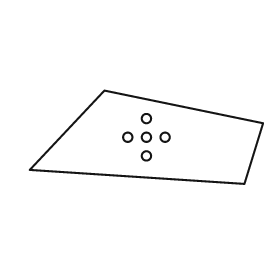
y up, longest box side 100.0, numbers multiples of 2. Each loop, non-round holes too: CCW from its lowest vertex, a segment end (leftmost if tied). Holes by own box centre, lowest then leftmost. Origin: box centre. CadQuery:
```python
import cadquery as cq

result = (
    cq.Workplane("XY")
    .moveTo(42.0, -20.0)
    .lineTo(50.0, 6.0)
    .lineTo(-18.0, 20.0)
    .lineTo(-50.0, -14.0)
    .close()
    .moveTo(0.0, -8.0)
    .circle(2.0)
    .moveTo(-8.0, 0.0)
    .circle(2.0)
    .moveTo(0.0, 0.0)
    .circle(2.0)
    .moveTo(8.0, 0.0)
    .circle(2.0)
    .moveTo(0.0, 8.0)
    .circle(2.0)
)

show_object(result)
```